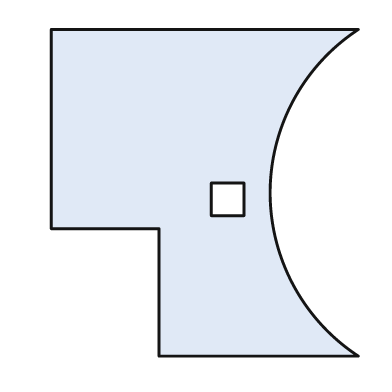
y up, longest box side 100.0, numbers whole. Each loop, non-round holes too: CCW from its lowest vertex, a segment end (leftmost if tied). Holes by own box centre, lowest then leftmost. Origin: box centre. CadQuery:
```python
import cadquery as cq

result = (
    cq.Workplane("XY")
    .moveTo(-14.0, -50.0)
    .lineTo(47.0, -50.0)
    .threePointArc((20.0, 0.0), (47.0, 50.0))
    .lineTo(-47.0, 50.0)
    .lineTo(-47.0, -11.0)
    .lineTo(-14.0, -11.0)
    .close()
    .moveTo(2.0, -7.0)
    .lineTo(12.0, -7.0)
    .lineTo(12.0, 3.0)
    .lineTo(2.0, 3.0)
    .close()
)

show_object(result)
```